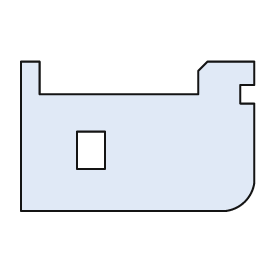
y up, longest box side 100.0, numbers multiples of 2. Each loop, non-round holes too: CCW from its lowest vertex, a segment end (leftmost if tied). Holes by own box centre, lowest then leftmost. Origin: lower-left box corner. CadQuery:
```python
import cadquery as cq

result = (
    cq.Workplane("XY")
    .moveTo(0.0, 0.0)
    .lineTo(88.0, 0.0)
    .threePointArc((96.0, 4.0), (100.0, 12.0))
    .lineTo(100.0, 46.0)
    .lineTo(94.0, 46.0)
    .lineTo(94.0, 54.0)
    .lineTo(100.0, 54.0)
    .lineTo(100.0, 64.0)
    .lineTo(80.0, 64.0)
    .lineTo(76.0, 60.0)
    .lineTo(76.0, 50.0)
    .lineTo(8.0, 50.0)
    .lineTo(8.0, 64.0)
    .lineTo(0.0, 64.0)
    .close()
    .moveTo(24.0, 18.0)
    .lineTo(36.0, 18.0)
    .lineTo(36.0, 34.0)
    .lineTo(24.0, 34.0)
    .close()
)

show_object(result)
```